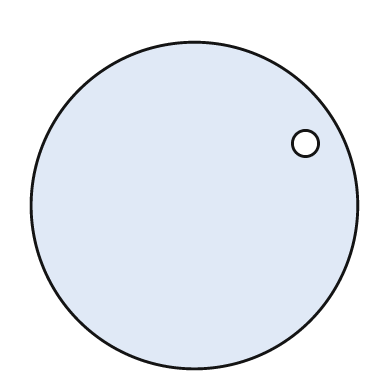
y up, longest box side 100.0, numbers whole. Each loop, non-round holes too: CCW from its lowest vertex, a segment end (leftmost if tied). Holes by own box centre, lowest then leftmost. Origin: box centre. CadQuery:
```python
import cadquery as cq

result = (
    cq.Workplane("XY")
    .moveTo(0.0, 0.0)
    .circle(50.0)
    .moveTo(34.0, 19.0)
    .circle(4.0)
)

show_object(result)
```